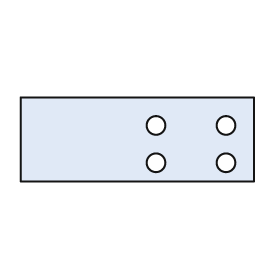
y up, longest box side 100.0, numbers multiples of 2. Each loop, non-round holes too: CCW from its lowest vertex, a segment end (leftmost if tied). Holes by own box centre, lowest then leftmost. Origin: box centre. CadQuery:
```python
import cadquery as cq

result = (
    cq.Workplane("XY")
    .moveTo(-50.0, -18.0)
    .lineTo(50.0, -18.0)
    .lineTo(50.0, 18.0)
    .lineTo(-50.0, 18.0)
    .close()
    .moveTo(8.0, -10.0)
    .circle(4.0)
    .moveTo(38.0, -10.0)
    .circle(4.0)
    .moveTo(8.0, 6.0)
    .circle(4.0)
    .moveTo(38.0, 6.0)
    .circle(4.0)
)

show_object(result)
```